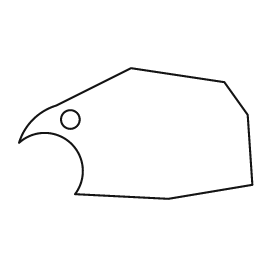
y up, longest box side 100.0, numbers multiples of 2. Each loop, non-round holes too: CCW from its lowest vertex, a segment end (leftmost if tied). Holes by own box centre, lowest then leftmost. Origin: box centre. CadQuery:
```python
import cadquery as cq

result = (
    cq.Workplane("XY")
    .moveTo(14.0, -28.0)
    .lineTo(50.0, -22.0)
    .lineTo(48.0, 8.0)
    .lineTo(38.0, 22.0)
    .lineTo(-2.0, 28.0)
    .lineTo(-34.0, 12.0)
    .threePointArc((-44.0, 6.0), (-50.0, -4.0))
    .threePointArc((-28.0, -4.0), (-26.0, -26.0))
    .close()
    .moveTo(-28.0, 6.0)
    .circle(4.0)
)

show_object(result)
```